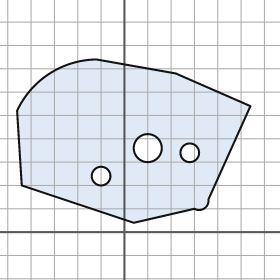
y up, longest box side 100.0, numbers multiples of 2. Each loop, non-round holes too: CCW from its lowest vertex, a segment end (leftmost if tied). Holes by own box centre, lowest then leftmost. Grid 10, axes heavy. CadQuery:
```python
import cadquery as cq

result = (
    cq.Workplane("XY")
    .moveTo(4.0, 4.0)
    .lineTo(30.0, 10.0)
    .threePointArc((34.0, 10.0), (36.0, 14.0))
    .lineTo(54.0, 54.0)
    .lineTo(22.0, 68.0)
    .lineTo(-12.0, 74.0)
    .threePointArc((-32.0, 68.0), (-46.0, 52.0))
    .lineTo(-44.0, 20.0)
    .close()
    .moveTo(-10.0, 24.0)
    .circle(4.0)
    .moveTo(28.0, 34.0)
    .circle(4.0)
    .moveTo(10.0, 36.0)
    .circle(6.0)
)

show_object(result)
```